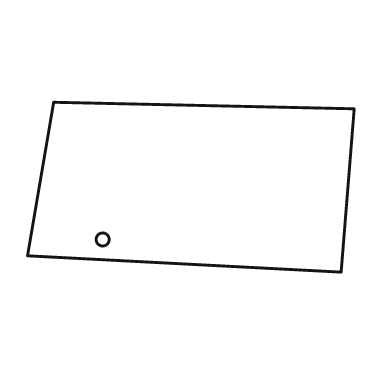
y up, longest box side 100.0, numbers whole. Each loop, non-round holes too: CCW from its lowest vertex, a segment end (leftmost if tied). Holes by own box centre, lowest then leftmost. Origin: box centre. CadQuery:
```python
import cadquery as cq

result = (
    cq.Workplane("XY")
    .moveTo(46.0, -26.0)
    .lineTo(50.0, 24.0)
    .lineTo(-42.0, 26.0)
    .lineTo(-50.0, -21.0)
    .close()
    .moveTo(-27.0, -16.0)
    .circle(2.0)
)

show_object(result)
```